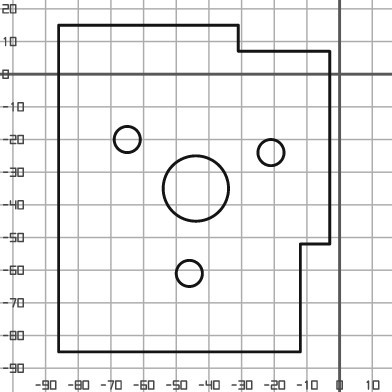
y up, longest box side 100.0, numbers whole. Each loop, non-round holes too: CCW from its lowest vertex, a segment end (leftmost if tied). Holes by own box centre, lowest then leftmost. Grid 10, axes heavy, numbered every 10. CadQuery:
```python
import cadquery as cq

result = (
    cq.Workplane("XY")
    .moveTo(-86.0, -85.0)
    .lineTo(-12.0, -85.0)
    .lineTo(-12.0, -52.0)
    .lineTo(-3.0, -52.0)
    .lineTo(-3.0, 7.0)
    .lineTo(-31.0, 7.0)
    .lineTo(-31.0, 15.0)
    .lineTo(-86.0, 15.0)
    .close()
    .moveTo(-46.0, -61.0)
    .circle(4.0)
    .moveTo(-44.0, -35.0)
    .circle(10.0)
    .moveTo(-21.0, -24.0)
    .circle(4.0)
    .moveTo(-65.0, -20.0)
    .circle(4.0)
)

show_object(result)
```